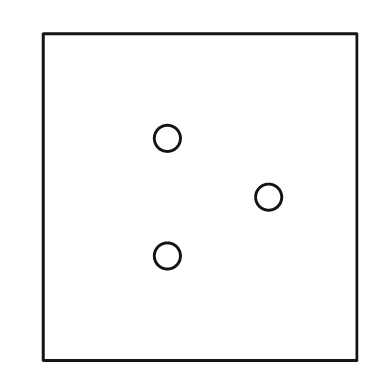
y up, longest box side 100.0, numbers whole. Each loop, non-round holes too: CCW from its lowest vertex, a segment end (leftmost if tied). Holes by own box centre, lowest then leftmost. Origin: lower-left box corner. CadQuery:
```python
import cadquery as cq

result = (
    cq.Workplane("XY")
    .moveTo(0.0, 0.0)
    .lineTo(96.0, 0.0)
    .lineTo(96.0, 100.0)
    .lineTo(0.0, 100.0)
    .close()
    .moveTo(38.0, 32.0)
    .circle(4.0)
    .moveTo(69.0, 50.0)
    .circle(4.0)
    .moveTo(38.0, 68.0)
    .circle(4.0)
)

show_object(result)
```